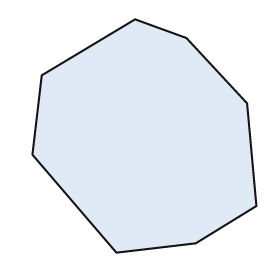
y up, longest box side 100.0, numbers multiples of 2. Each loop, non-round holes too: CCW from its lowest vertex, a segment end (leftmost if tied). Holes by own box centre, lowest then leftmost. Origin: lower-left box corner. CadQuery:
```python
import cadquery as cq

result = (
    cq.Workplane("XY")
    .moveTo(36.0, 0.0)
    .lineTo(70.0, 4.0)
    .lineTo(96.0, 20.0)
    .lineTo(92.0, 64.0)
    .lineTo(66.0, 92.0)
    .lineTo(44.0, 100.0)
    .lineTo(4.0, 76.0)
    .lineTo(0.0, 42.0)
    .close()
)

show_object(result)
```